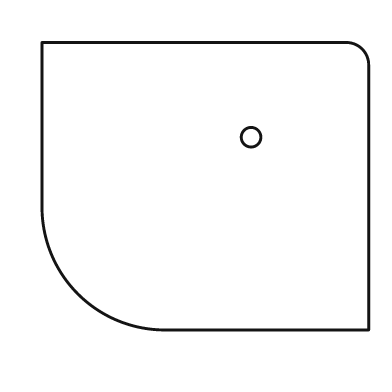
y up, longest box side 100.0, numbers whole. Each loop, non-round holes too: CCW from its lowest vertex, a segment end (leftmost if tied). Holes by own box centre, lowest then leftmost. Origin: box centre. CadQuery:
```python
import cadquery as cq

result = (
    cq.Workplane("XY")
    .moveTo(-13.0, -44.0)
    .lineTo(50.0, -44.0)
    .lineTo(50.0, 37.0)
    .threePointArc((48.0, 42.0), (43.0, 44.0))
    .lineTo(-50.0, 44.0)
    .lineTo(-50.0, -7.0)
    .threePointArc((-39.0, -33.0), (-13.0, -44.0))
    .close()
    .moveTo(14.0, 15.0)
    .circle(3.0)
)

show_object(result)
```